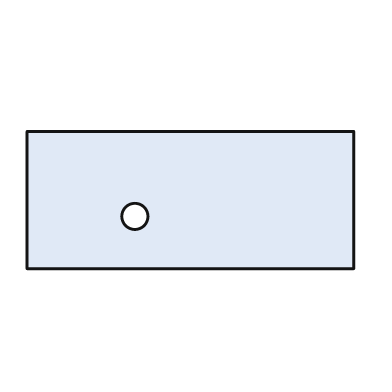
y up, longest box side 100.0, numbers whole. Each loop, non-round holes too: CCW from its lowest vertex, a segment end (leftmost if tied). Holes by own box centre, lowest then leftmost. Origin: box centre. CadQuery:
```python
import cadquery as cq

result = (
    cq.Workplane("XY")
    .moveTo(-50.0, -21.0)
    .lineTo(50.0, -21.0)
    .lineTo(50.0, 21.0)
    .lineTo(-50.0, 21.0)
    .close()
    .moveTo(-17.0, -5.0)
    .circle(4.0)
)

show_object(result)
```